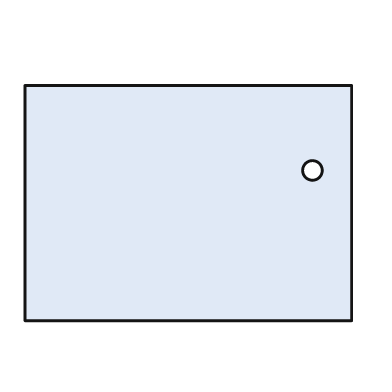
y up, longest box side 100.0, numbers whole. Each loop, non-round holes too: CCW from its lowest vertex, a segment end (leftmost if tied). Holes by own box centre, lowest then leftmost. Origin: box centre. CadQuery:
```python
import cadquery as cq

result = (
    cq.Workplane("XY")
    .moveTo(-50.0, -36.0)
    .lineTo(50.0, -36.0)
    .lineTo(50.0, 36.0)
    .lineTo(-50.0, 36.0)
    .close()
    .moveTo(38.0, 10.0)
    .circle(3.0)
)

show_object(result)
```